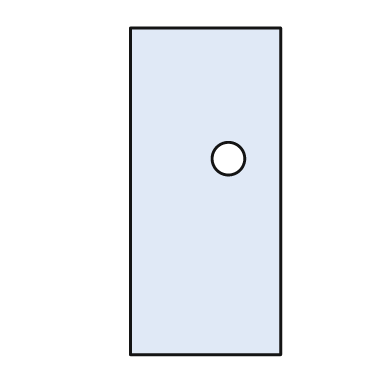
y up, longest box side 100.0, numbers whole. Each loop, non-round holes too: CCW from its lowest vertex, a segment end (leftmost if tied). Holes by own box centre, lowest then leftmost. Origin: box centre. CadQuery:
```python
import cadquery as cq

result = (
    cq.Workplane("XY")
    .moveTo(-23.0, -50.0)
    .lineTo(23.0, -50.0)
    .lineTo(23.0, 50.0)
    .lineTo(-23.0, 50.0)
    .close()
    .moveTo(7.0, 10.0)
    .circle(5.0)
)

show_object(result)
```